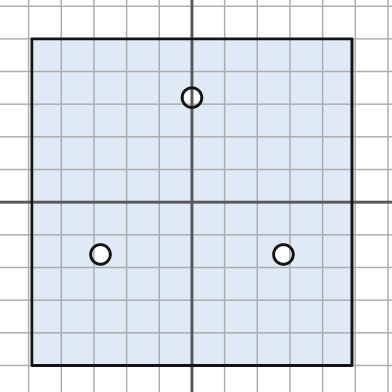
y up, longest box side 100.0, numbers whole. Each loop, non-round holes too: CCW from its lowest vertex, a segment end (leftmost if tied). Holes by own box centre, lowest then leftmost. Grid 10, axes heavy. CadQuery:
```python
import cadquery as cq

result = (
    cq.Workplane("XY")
    .moveTo(-49.0, -50.0)
    .lineTo(49.0, -50.0)
    .lineTo(49.0, 50.0)
    .lineTo(-49.0, 50.0)
    .close()
    .moveTo(-28.0, -16.0)
    .circle(3.0)
    .moveTo(28.0, -16.0)
    .circle(3.0)
    .moveTo(0.0, 32.0)
    .circle(3.0)
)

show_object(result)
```